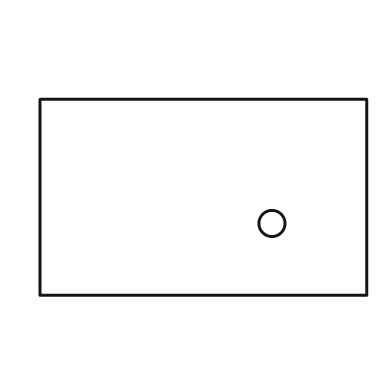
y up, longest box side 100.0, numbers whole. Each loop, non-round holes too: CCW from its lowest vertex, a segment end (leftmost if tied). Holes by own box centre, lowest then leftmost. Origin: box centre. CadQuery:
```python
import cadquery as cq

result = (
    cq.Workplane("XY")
    .moveTo(-50.0, -30.0)
    .lineTo(50.0, -30.0)
    .lineTo(50.0, 30.0)
    .lineTo(-50.0, 30.0)
    .close()
    .moveTo(21.0, -8.0)
    .circle(4.0)
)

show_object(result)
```